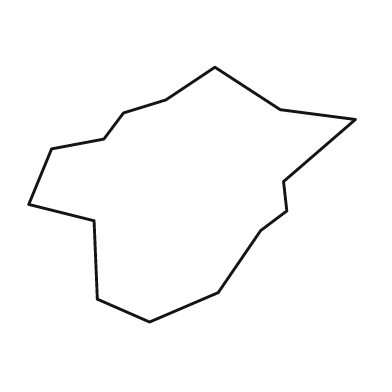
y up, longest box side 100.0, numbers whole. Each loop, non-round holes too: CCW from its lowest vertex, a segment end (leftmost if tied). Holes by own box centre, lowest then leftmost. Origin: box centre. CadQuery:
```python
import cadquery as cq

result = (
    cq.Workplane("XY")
    .moveTo(-13.0, -39.0)
    .lineTo(8.0, -30.0)
    .lineTo(21.0, -11.0)
    .lineTo(29.0, -5.0)
    .lineTo(28.0, 4.0)
    .lineTo(50.0, 23.0)
    .lineTo(27.0, 26.0)
    .lineTo(7.0, 39.0)
    .lineTo(-8.0, 29.0)
    .lineTo(-21.0, 25.0)
    .lineTo(-27.0, 17.0)
    .lineTo(-43.0, 14.0)
    .lineTo(-50.0, -3.0)
    .lineTo(-30.0, -8.0)
    .lineTo(-29.0, -32.0)
    .close()
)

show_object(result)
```